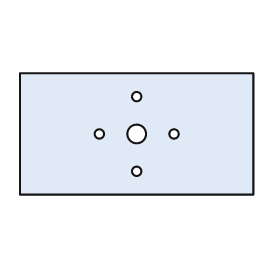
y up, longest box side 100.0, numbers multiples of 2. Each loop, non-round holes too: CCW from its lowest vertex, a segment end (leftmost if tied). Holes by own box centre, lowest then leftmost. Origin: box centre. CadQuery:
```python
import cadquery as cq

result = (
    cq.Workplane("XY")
    .moveTo(-50.0, -26.0)
    .lineTo(50.0, -26.0)
    .lineTo(50.0, 26.0)
    .lineTo(-50.0, 26.0)
    .close()
    .moveTo(0.0, -16.0)
    .circle(2.0)
    .moveTo(-16.0, 0.0)
    .circle(2.0)
    .moveTo(0.0, 0.0)
    .circle(4.0)
    .moveTo(16.0, 0.0)
    .circle(2.0)
    .moveTo(0.0, 16.0)
    .circle(2.0)
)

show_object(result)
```